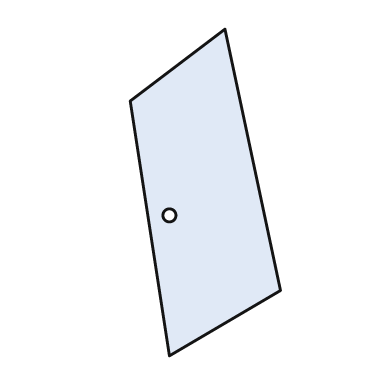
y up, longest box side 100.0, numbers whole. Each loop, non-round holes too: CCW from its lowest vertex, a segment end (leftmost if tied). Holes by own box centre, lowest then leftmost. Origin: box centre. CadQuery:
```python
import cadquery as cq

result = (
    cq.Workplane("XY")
    .moveTo(-11.0, -50.0)
    .lineTo(23.0, -30.0)
    .lineTo(6.0, 50.0)
    .lineTo(-23.0, 28.0)
    .close()
    .moveTo(-11.0, -7.0)
    .circle(2.0)
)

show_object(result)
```